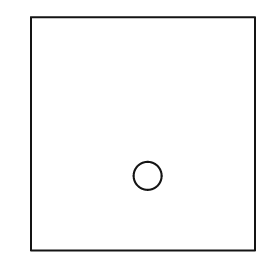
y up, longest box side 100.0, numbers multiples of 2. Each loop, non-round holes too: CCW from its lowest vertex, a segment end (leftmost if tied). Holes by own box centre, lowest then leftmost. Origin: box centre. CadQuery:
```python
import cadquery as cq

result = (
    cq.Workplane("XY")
    .moveTo(-48.0, -50.0)
    .lineTo(48.0, -50.0)
    .lineTo(48.0, 50.0)
    .lineTo(-48.0, 50.0)
    .close()
    .moveTo(2.0, -18.0)
    .circle(6.0)
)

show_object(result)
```